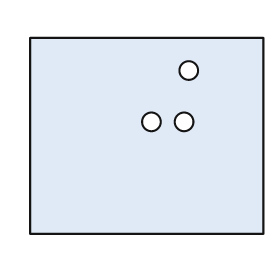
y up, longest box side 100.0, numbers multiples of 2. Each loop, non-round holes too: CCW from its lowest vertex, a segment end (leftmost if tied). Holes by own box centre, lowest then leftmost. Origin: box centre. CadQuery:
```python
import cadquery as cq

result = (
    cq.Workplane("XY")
    .moveTo(-50.0, -42.0)
    .lineTo(50.0, -42.0)
    .lineTo(50.0, 42.0)
    .lineTo(-50.0, 42.0)
    .close()
    .moveTo(2.0, 6.0)
    .circle(4.0)
    .moveTo(16.0, 6.0)
    .circle(4.0)
    .moveTo(18.0, 28.0)
    .circle(4.0)
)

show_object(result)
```